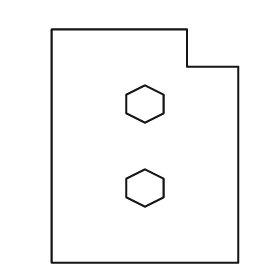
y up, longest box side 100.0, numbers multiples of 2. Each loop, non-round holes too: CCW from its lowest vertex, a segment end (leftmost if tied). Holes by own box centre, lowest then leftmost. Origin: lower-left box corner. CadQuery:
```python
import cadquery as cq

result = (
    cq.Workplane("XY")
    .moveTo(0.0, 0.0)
    .lineTo(80.0, 0.0)
    .lineTo(80.0, 84.0)
    .lineTo(58.0, 84.0)
    .lineTo(58.0, 100.0)
    .lineTo(0.0, 100.0)
    .close()
    .moveTo(40.0, 24.0)
    .lineTo(48.0, 28.0)
    .lineTo(48.0, 36.0)
    .lineTo(40.0, 40.0)
    .lineTo(32.0, 36.0)
    .lineTo(32.0, 28.0)
    .close()
    .moveTo(40.0, 60.0)
    .lineTo(48.0, 64.0)
    .lineTo(48.0, 72.0)
    .lineTo(40.0, 76.0)
    .lineTo(32.0, 72.0)
    .lineTo(32.0, 64.0)
    .close()
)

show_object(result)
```